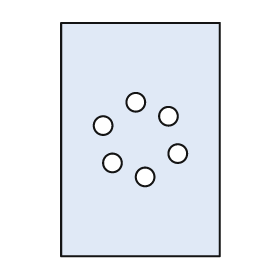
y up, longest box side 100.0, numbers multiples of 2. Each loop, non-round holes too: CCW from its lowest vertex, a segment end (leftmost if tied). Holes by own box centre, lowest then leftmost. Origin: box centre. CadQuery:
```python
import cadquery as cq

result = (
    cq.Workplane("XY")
    .moveTo(-34.0, -50.0)
    .lineTo(34.0, -50.0)
    .lineTo(34.0, 50.0)
    .lineTo(-34.0, 50.0)
    .close()
    .moveTo(2.0, -16.0)
    .circle(4.0)
    .moveTo(-12.0, -10.0)
    .circle(4.0)
    .moveTo(16.0, -6.0)
    .circle(4.0)
    .moveTo(-16.0, 6.0)
    .circle(4.0)
    .moveTo(12.0, 10.0)
    .circle(4.0)
    .moveTo(-2.0, 16.0)
    .circle(4.0)
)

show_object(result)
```